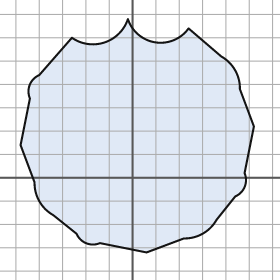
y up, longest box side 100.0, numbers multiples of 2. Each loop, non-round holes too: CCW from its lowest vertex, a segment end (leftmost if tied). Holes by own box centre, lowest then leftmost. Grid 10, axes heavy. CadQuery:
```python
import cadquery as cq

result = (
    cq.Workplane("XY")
    .moveTo(6.0, -32.0)
    .lineTo(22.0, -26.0)
    .threePointArc((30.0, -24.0), (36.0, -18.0))
    .lineTo(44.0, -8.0)
    .threePointArc((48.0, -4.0), (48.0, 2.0))
    .lineTo(52.0, 22.0)
    .lineTo(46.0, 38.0)
    .threePointArc((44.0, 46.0), (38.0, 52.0))
    .lineTo(24.0, 64.0)
    .threePointArc((10.0, 58.0), (-2.0, 68.0))
    .threePointArc((-12.0, 58.0), (-26.0, 60.0))
    .lineTo(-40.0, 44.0)
    .threePointArc((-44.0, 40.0), (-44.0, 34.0))
    .lineTo(-48.0, 14.0)
    .lineTo(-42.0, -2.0)
    .threePointArc((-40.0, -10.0), (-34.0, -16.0))
    .lineTo(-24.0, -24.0)
    .threePointArc((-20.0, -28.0), (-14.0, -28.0))
    .close()
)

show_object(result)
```